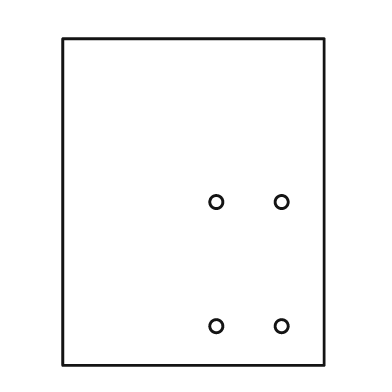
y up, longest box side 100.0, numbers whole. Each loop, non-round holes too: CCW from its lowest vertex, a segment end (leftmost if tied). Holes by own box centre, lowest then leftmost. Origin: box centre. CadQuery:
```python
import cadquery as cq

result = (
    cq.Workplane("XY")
    .moveTo(-40.0, -50.0)
    .lineTo(40.0, -50.0)
    .lineTo(40.0, 50.0)
    .lineTo(-40.0, 50.0)
    .close()
    .moveTo(7.0, -38.0)
    .circle(2.0)
    .moveTo(27.0, -38.0)
    .circle(2.0)
    .moveTo(7.0, 0.0)
    .circle(2.0)
    .moveTo(27.0, 0.0)
    .circle(2.0)
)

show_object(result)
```